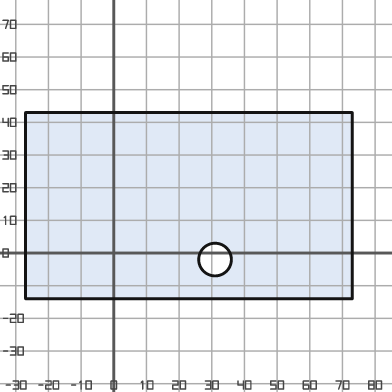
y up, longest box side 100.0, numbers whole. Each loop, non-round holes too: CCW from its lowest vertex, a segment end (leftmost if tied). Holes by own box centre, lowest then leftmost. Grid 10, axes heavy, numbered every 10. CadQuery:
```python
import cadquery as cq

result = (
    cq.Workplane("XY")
    .moveTo(-27.0, -14.0)
    .lineTo(73.0, -14.0)
    .lineTo(73.0, 43.0)
    .lineTo(-27.0, 43.0)
    .close()
    .moveTo(31.0, -2.0)
    .circle(5.0)
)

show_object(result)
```